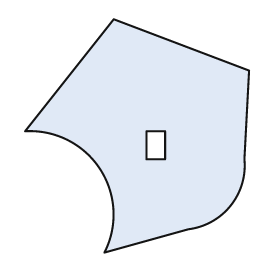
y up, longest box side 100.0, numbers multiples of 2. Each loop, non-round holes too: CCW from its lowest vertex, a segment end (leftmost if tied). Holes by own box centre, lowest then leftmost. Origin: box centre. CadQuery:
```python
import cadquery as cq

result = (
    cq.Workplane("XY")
    .moveTo(-14.0, -50.0)
    .lineTo(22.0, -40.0)
    .threePointArc((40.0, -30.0), (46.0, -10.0))
    .lineTo(48.0, 28.0)
    .lineTo(-10.0, 50.0)
    .lineTo(-48.0, 2.0)
    .threePointArc((-16.0, -14.0), (-14.0, -50.0))
    .close()
    .moveTo(4.0, -10.0)
    .lineTo(12.0, -10.0)
    .lineTo(12.0, 2.0)
    .lineTo(4.0, 2.0)
    .close()
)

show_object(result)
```